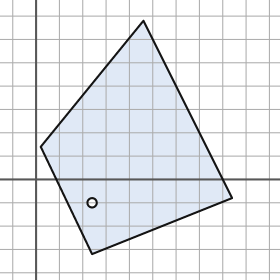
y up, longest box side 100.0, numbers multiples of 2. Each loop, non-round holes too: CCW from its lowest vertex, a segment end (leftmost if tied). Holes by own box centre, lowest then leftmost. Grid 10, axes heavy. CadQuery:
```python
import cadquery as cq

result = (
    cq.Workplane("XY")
    .moveTo(24.0, -32.0)
    .lineTo(84.0, -8.0)
    .lineTo(46.0, 68.0)
    .lineTo(2.0, 14.0)
    .close()
    .moveTo(24.0, -10.0)
    .circle(2.0)
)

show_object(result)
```